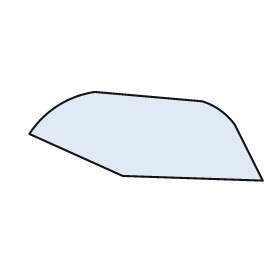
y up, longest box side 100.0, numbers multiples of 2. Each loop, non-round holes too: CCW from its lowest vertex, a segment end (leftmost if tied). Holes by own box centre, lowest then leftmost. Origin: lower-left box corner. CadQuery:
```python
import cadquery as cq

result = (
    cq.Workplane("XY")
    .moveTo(100.0, 0.0)
    .lineTo(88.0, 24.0)
    .threePointArc((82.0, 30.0), (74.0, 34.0))
    .lineTo(28.0, 38.0)
    .threePointArc((12.0, 32.0), (0.0, 20.0))
    .lineTo(40.0, 2.0)
    .close()
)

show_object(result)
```